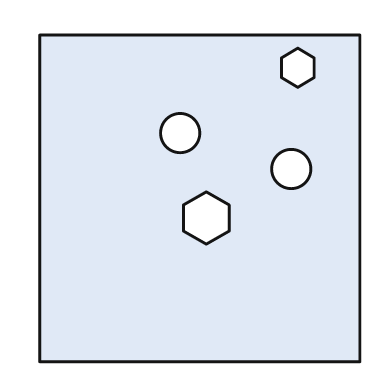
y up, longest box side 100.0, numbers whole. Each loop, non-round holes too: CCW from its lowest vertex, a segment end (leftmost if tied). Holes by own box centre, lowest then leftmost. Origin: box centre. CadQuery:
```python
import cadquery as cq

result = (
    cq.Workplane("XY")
    .moveTo(-49.0, -50.0)
    .lineTo(49.0, -50.0)
    .lineTo(49.0, 50.0)
    .lineTo(-49.0, 50.0)
    .close()
    .moveTo(2.0, -14.0)
    .lineTo(9.0, -10.0)
    .lineTo(9.0, -2.0)
    .lineTo(2.0, 2.0)
    .lineTo(-5.0, -2.0)
    .lineTo(-5.0, -10.0)
    .close()
    .moveTo(28.0, 9.0)
    .circle(6.0)
    .moveTo(-6.0, 20.0)
    .circle(6.0)
    .moveTo(30.0, 34.0)
    .lineTo(35.0, 37.0)
    .lineTo(35.0, 43.0)
    .lineTo(30.0, 46.0)
    .lineTo(25.0, 43.0)
    .lineTo(25.0, 37.0)
    .close()
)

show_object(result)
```